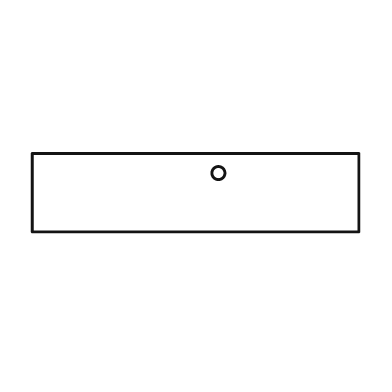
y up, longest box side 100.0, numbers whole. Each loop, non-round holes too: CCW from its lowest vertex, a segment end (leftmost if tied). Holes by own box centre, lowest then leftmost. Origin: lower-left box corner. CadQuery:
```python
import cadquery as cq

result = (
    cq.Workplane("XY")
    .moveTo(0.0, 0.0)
    .lineTo(100.0, 0.0)
    .lineTo(100.0, 24.0)
    .lineTo(0.0, 24.0)
    .close()
    .moveTo(57.0, 18.0)
    .circle(2.0)
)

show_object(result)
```